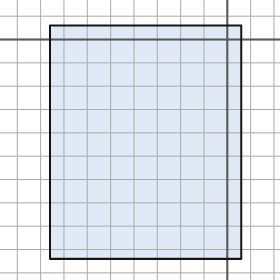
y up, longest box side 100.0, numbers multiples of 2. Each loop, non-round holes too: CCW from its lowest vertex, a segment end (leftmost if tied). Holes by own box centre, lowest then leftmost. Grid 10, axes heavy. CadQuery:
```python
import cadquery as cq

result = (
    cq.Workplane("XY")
    .moveTo(-76.0, -94.0)
    .lineTo(6.0, -94.0)
    .lineTo(6.0, 6.0)
    .lineTo(-76.0, 6.0)
    .close()
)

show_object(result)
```